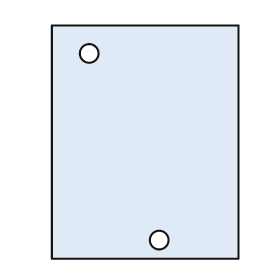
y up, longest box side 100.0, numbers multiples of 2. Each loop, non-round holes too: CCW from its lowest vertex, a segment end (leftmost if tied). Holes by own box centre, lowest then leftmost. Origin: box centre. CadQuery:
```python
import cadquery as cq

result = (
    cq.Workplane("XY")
    .moveTo(-40.0, -50.0)
    .lineTo(40.0, -50.0)
    .lineTo(40.0, 50.0)
    .lineTo(-40.0, 50.0)
    .close()
    .moveTo(6.0, -42.0)
    .circle(4.0)
    .moveTo(-24.0, 38.0)
    .circle(4.0)
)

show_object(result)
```